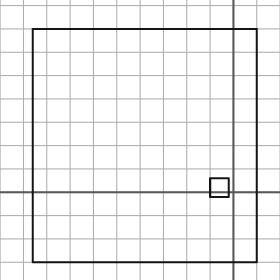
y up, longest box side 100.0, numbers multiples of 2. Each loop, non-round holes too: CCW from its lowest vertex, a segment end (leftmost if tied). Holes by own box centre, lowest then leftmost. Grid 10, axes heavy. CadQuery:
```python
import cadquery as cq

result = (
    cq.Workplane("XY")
    .moveTo(-86.0, -30.0)
    .lineTo(10.0, -30.0)
    .lineTo(10.0, 70.0)
    .lineTo(-86.0, 70.0)
    .close()
    .moveTo(-10.0, -2.0)
    .lineTo(-2.0, -2.0)
    .lineTo(-2.0, 6.0)
    .lineTo(-10.0, 6.0)
    .close()
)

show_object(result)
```